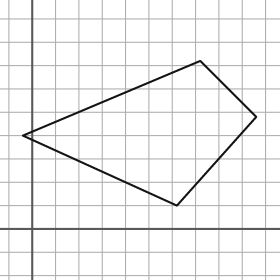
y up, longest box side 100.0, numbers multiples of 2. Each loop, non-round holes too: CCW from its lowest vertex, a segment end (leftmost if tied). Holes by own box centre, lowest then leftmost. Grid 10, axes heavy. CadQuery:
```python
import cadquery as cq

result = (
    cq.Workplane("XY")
    .moveTo(62.0, 10.0)
    .lineTo(96.0, 48.0)
    .lineTo(72.0, 72.0)
    .lineTo(-4.0, 40.0)
    .close()
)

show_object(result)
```